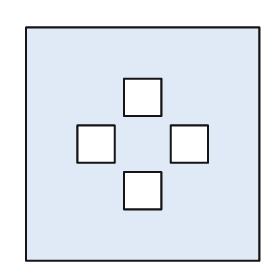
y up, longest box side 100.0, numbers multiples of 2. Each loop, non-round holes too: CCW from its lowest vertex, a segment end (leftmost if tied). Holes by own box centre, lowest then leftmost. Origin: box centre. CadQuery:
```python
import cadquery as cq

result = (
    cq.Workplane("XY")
    .moveTo(-50.0, -50.0)
    .lineTo(50.0, -50.0)
    .lineTo(50.0, 50.0)
    .lineTo(-50.0, 50.0)
    .close()
    .moveTo(-8.0, -28.0)
    .lineTo(8.0, -28.0)
    .lineTo(8.0, -12.0)
    .lineTo(-8.0, -12.0)
    .close()
    .moveTo(-28.0, -8.0)
    .lineTo(-12.0, -8.0)
    .lineTo(-12.0, 8.0)
    .lineTo(-28.0, 8.0)
    .close()
    .moveTo(12.0, -8.0)
    .lineTo(28.0, -8.0)
    .lineTo(28.0, 8.0)
    .lineTo(12.0, 8.0)
    .close()
    .moveTo(-8.0, 12.0)
    .lineTo(8.0, 12.0)
    .lineTo(8.0, 28.0)
    .lineTo(-8.0, 28.0)
    .close()
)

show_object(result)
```